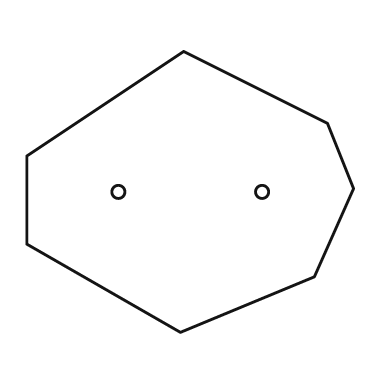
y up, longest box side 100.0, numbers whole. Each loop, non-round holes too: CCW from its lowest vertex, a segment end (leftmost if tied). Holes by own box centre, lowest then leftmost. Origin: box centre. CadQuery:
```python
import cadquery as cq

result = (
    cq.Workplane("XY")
    .moveTo(-3.0, -43.0)
    .lineTo(38.0, -26.0)
    .lineTo(50.0, 1.0)
    .lineTo(42.0, 21.0)
    .lineTo(-2.0, 43.0)
    .lineTo(-50.0, 11.0)
    .lineTo(-50.0, -16.0)
    .close()
    .moveTo(-22.0, 0.0)
    .circle(2.0)
    .moveTo(22.0, 0.0)
    .circle(2.0)
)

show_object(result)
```